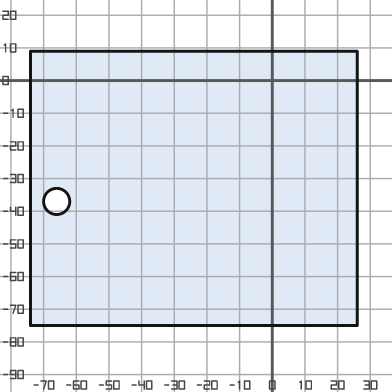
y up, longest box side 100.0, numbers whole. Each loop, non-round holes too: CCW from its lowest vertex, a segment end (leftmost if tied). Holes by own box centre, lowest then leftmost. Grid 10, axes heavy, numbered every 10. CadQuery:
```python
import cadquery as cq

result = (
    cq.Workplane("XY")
    .moveTo(-74.0, -75.0)
    .lineTo(26.0, -75.0)
    .lineTo(26.0, 9.0)
    .lineTo(-74.0, 9.0)
    .close()
    .moveTo(-66.0, -37.0)
    .circle(4.0)
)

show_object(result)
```